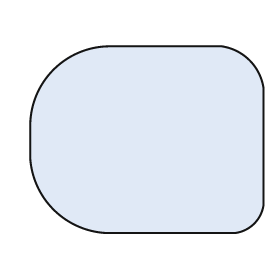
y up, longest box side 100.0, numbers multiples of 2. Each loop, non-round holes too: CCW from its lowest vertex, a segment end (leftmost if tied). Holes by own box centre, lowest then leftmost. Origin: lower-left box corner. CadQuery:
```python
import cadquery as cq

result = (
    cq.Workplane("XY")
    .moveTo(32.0, 0.0)
    .lineTo(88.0, 0.0)
    .threePointArc((96.0, 4.0), (100.0, 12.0))
    .lineTo(100.0, 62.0)
    .threePointArc((94.0, 74.0), (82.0, 80.0))
    .lineTo(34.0, 80.0)
    .threePointArc((10.0, 70.0), (0.0, 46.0))
    .lineTo(0.0, 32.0)
    .threePointArc((10.0, 10.0), (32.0, 0.0))
    .close()
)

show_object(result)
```